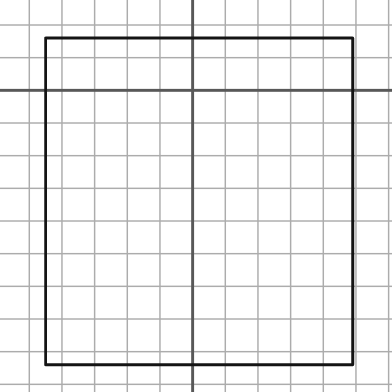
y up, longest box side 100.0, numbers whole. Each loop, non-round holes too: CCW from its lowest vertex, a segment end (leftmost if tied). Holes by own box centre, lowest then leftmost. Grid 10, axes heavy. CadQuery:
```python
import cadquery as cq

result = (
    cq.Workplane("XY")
    .moveTo(-45.0, -84.0)
    .lineTo(49.0, -84.0)
    .lineTo(49.0, 16.0)
    .lineTo(-45.0, 16.0)
    .close()
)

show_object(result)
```